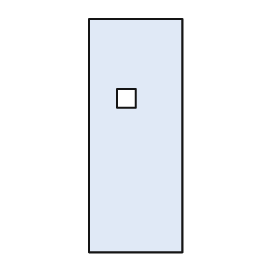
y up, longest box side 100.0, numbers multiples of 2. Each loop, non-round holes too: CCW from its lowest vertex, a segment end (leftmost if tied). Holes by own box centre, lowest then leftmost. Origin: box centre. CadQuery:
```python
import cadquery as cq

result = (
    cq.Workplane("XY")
    .moveTo(-20.0, -50.0)
    .lineTo(20.0, -50.0)
    .lineTo(20.0, 50.0)
    .lineTo(-20.0, 50.0)
    .close()
    .moveTo(-8.0, 12.0)
    .lineTo(0.0, 12.0)
    .lineTo(0.0, 20.0)
    .lineTo(-8.0, 20.0)
    .close()
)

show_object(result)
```